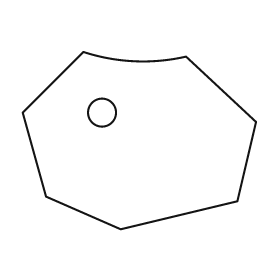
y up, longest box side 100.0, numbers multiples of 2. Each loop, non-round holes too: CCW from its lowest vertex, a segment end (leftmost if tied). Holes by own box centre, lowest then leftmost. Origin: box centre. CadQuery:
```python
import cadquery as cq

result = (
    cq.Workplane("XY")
    .moveTo(-8.0, -38.0)
    .lineTo(42.0, -26.0)
    .lineTo(50.0, 8.0)
    .lineTo(20.0, 36.0)
    .threePointArc((-2.0, 34.0), (-24.0, 38.0))
    .lineTo(-50.0, 12.0)
    .lineTo(-40.0, -24.0)
    .close()
    .moveTo(-16.0, 12.0)
    .circle(6.0)
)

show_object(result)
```